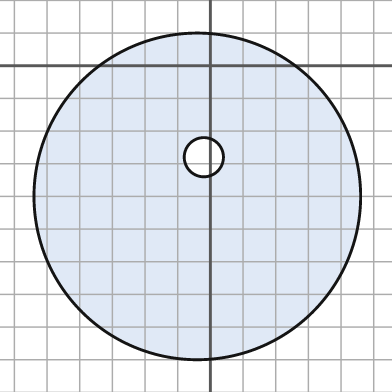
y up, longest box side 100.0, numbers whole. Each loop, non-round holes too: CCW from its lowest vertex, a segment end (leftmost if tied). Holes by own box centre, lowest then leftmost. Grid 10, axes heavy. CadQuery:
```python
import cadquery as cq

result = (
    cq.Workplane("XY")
    .moveTo(-4.0, -40.0)
    .circle(50.0)
    .moveTo(-2.0, -28.0)
    .circle(6.0)
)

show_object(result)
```